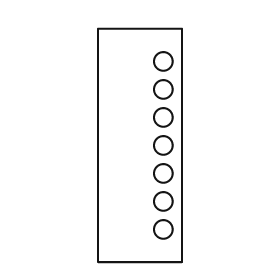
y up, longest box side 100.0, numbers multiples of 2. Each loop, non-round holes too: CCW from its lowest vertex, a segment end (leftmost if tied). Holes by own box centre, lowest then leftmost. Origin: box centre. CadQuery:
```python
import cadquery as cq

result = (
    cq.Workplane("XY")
    .moveTo(-18.0, -50.0)
    .lineTo(18.0, -50.0)
    .lineTo(18.0, 50.0)
    .lineTo(-18.0, 50.0)
    .close()
    .moveTo(10.0, -36.0)
    .circle(4.0)
    .moveTo(10.0, -24.0)
    .circle(4.0)
    .moveTo(10.0, -12.0)
    .circle(4.0)
    .moveTo(10.0, 0.0)
    .circle(4.0)
    .moveTo(10.0, 12.0)
    .circle(4.0)
    .moveTo(10.0, 24.0)
    .circle(4.0)
    .moveTo(10.0, 36.0)
    .circle(4.0)
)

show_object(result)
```